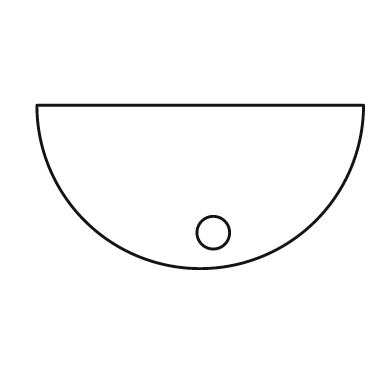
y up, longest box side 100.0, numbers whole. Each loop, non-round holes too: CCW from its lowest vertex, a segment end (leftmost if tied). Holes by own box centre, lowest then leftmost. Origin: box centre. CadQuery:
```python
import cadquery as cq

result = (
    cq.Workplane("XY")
    .moveTo(-50.0, 25.0)
    .threePointArc((0.0, -25.0), (50.0, 25.0))
    .close()
    .moveTo(4.0, -14.0)
    .circle(5.0)
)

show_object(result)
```